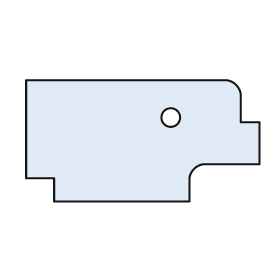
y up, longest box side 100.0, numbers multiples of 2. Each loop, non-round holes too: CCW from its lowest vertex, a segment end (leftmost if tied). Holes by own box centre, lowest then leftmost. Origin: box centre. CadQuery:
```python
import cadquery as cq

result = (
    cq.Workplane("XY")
    .moveTo(-38.0, -26.0)
    .lineTo(20.0, -26.0)
    .lineTo(20.0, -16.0)
    .threePointArc((22.0, -12.0), (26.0, -10.0))
    .lineTo(50.0, -10.0)
    .lineTo(50.0, 8.0)
    .lineTo(42.0, 8.0)
    .lineTo(42.0, 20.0)
    .threePointArc((40.0, 24.0), (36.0, 26.0))
    .lineTo(-50.0, 26.0)
    .lineTo(-50.0, -16.0)
    .lineTo(-38.0, -16.0)
    .close()
    .moveTo(12.0, 10.0)
    .circle(4.0)
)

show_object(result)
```